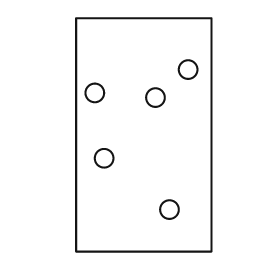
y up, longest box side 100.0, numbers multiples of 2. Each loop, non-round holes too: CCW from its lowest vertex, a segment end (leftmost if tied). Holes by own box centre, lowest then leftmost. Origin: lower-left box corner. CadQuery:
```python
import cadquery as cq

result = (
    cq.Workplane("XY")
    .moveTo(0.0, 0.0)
    .lineTo(58.0, 0.0)
    .lineTo(58.0, 100.0)
    .lineTo(0.0, 100.0)
    .close()
    .moveTo(40.0, 18.0)
    .circle(4.0)
    .moveTo(12.0, 40.0)
    .circle(4.0)
    .moveTo(34.0, 66.0)
    .circle(4.0)
    .moveTo(8.0, 68.0)
    .circle(4.0)
    .moveTo(48.0, 78.0)
    .circle(4.0)
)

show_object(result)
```